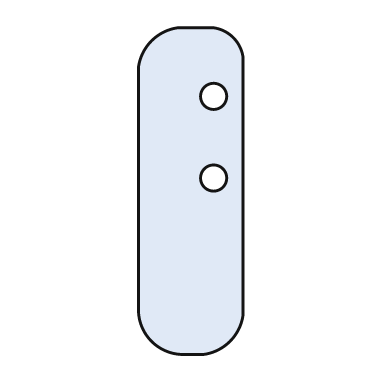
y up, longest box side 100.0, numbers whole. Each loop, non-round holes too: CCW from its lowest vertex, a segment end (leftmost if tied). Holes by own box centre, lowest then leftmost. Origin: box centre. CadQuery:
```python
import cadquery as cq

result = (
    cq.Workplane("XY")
    .moveTo(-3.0, -50.0)
    .lineTo(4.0, -50.0)
    .threePointArc((12.0, -46.0), (16.0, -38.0))
    .lineTo(16.0, 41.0)
    .threePointArc((13.0, 47.0), (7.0, 50.0))
    .lineTo(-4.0, 50.0)
    .threePointArc((-12.0, 46.0), (-16.0, 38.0))
    .lineTo(-16.0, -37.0)
    .threePointArc((-12.0, -46.0), (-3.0, -50.0))
    .close()
    .moveTo(7.0, 4.0)
    .circle(4.0)
    .moveTo(7.0, 29.0)
    .circle(4.0)
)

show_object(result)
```